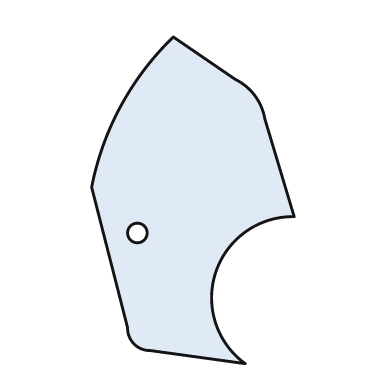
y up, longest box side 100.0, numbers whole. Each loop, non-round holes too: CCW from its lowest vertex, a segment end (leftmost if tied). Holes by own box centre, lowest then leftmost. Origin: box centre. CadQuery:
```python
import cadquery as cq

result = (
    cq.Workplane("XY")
    .moveTo(16.0, -50.0)
    .threePointArc((7.0, -22.0), (31.0, -5.0))
    .lineTo(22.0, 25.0)
    .threePointArc((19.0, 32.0), (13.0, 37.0))
    .lineTo(-6.0, 50.0)
    .threePointArc((-22.0, 29.0), (-31.0, 4.0))
    .lineTo(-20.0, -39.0)
    .threePointArc((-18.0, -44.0), (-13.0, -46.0))
    .close()
    .moveTo(-17.0, -10.0)
    .circle(3.0)
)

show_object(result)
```